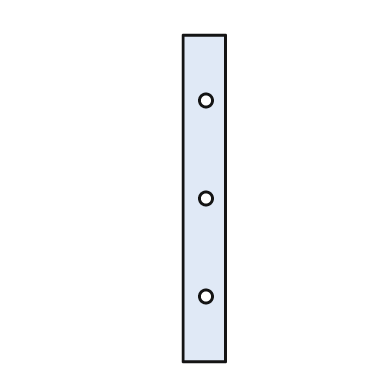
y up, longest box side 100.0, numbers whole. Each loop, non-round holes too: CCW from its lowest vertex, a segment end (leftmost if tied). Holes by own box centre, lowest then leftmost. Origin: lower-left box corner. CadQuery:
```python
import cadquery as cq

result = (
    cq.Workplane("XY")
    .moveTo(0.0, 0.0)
    .lineTo(13.0, 0.0)
    .lineTo(13.0, 100.0)
    .lineTo(0.0, 100.0)
    .close()
    .moveTo(7.0, 20.0)
    .circle(2.0)
    .moveTo(7.0, 50.0)
    .circle(2.0)
    .moveTo(7.0, 80.0)
    .circle(2.0)
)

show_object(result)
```